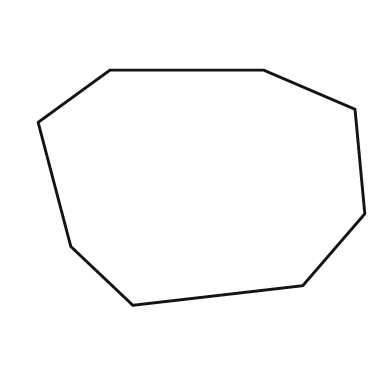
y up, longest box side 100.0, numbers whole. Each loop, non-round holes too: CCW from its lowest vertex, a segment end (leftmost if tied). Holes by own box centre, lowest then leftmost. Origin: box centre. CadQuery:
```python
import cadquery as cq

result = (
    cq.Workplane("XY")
    .moveTo(-21.0, -36.0)
    .lineTo(31.0, -30.0)
    .lineTo(50.0, -8.0)
    .lineTo(47.0, 24.0)
    .lineTo(19.0, 36.0)
    .lineTo(-28.0, 36.0)
    .lineTo(-50.0, 20.0)
    .lineTo(-40.0, -18.0)
    .close()
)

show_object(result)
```